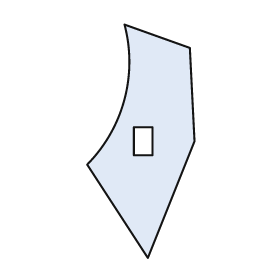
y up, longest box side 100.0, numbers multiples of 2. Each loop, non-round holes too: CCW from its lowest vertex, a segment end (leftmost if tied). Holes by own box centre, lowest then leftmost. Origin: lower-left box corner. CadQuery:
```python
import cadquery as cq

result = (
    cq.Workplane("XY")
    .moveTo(26.0, 0.0)
    .lineTo(46.0, 50.0)
    .lineTo(44.0, 90.0)
    .lineTo(16.0, 100.0)
    .threePointArc((16.0, 68.0), (0.0, 40.0))
    .close()
    .moveTo(20.0, 44.0)
    .lineTo(28.0, 44.0)
    .lineTo(28.0, 56.0)
    .lineTo(20.0, 56.0)
    .close()
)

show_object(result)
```